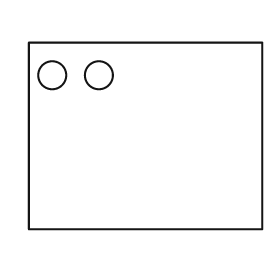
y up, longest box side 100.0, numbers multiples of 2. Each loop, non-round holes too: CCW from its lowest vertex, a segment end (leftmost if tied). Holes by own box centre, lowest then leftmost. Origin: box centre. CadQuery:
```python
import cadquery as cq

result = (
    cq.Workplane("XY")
    .moveTo(-50.0, -40.0)
    .lineTo(50.0, -40.0)
    .lineTo(50.0, 40.0)
    .lineTo(-50.0, 40.0)
    .close()
    .moveTo(-40.0, 26.0)
    .circle(6.0)
    .moveTo(-20.0, 26.0)
    .circle(6.0)
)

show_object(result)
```